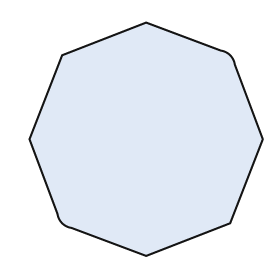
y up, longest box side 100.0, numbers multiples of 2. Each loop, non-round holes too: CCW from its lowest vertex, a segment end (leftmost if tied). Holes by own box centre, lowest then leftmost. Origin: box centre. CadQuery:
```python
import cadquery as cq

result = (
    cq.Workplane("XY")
    .moveTo(0.0, -50.0)
    .lineTo(36.0, -36.0)
    .lineTo(50.0, 0.0)
    .lineTo(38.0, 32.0)
    .threePointArc((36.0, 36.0), (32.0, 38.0))
    .lineTo(0.0, 50.0)
    .lineTo(-36.0, 36.0)
    .lineTo(-50.0, 0.0)
    .lineTo(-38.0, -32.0)
    .threePointArc((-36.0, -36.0), (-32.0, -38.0))
    .close()
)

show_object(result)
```